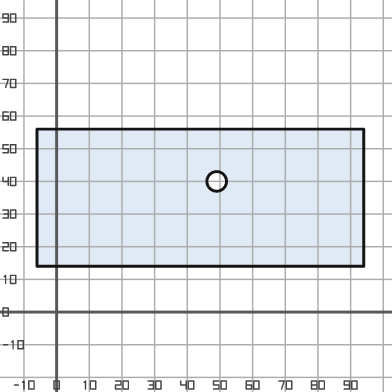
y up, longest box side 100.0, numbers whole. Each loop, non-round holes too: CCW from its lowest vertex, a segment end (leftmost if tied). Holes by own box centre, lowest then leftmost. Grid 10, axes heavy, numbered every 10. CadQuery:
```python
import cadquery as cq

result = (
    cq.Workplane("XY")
    .moveTo(-6.0, 14.0)
    .lineTo(94.0, 14.0)
    .lineTo(94.0, 56.0)
    .lineTo(-6.0, 56.0)
    .close()
    .moveTo(49.0, 40.0)
    .circle(3.0)
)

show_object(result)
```